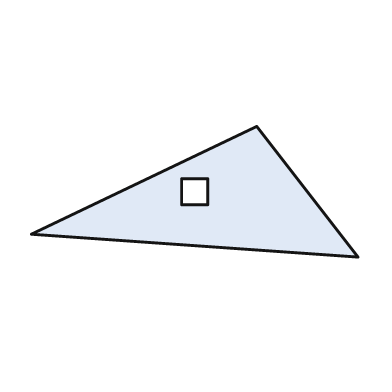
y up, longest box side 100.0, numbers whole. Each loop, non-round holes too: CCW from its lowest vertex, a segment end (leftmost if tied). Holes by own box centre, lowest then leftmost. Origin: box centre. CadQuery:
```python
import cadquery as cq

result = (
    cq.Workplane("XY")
    .moveTo(50.0, -20.0)
    .lineTo(19.0, 20.0)
    .lineTo(-50.0, -13.0)
    .close()
    .moveTo(-4.0, -4.0)
    .lineTo(4.0, -4.0)
    .lineTo(4.0, 4.0)
    .lineTo(-4.0, 4.0)
    .close()
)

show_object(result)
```